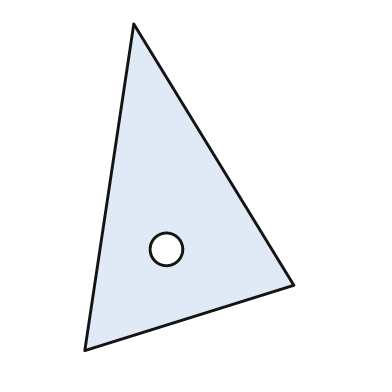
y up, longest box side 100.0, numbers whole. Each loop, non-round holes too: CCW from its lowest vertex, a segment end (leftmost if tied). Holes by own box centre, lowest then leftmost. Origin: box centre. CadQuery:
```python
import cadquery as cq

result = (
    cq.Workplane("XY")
    .moveTo(-32.0, -50.0)
    .lineTo(32.0, -30.0)
    .lineTo(-17.0, 50.0)
    .close()
    .moveTo(-7.0, -19.0)
    .circle(5.0)
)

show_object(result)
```